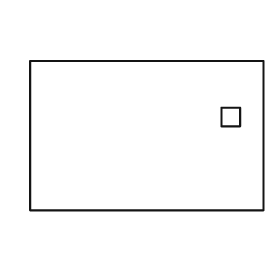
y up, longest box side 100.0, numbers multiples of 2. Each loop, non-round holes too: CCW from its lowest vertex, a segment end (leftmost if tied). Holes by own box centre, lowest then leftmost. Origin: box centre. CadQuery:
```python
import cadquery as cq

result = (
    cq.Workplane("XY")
    .moveTo(-50.0, -32.0)
    .lineTo(50.0, -32.0)
    .lineTo(50.0, 32.0)
    .lineTo(-50.0, 32.0)
    .close()
    .moveTo(32.0, 4.0)
    .lineTo(40.0, 4.0)
    .lineTo(40.0, 12.0)
    .lineTo(32.0, 12.0)
    .close()
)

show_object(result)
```